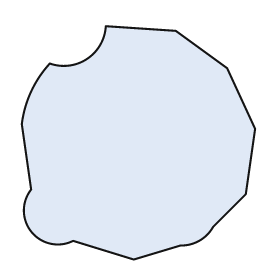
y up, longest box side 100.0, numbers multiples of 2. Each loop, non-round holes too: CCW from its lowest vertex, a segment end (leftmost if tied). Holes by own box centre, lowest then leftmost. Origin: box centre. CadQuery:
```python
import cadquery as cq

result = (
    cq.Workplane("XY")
    .moveTo(-2.0, -50.0)
    .lineTo(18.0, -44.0)
    .threePointArc((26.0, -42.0), (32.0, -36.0))
    .lineTo(46.0, -22.0)
    .lineTo(50.0, 6.0)
    .lineTo(38.0, 32.0)
    .lineTo(16.0, 48.0)
    .lineTo(-14.0, 50.0)
    .threePointArc((-22.0, 36.0), (-38.0, 34.0))
    .threePointArc((-46.0, 22.0), (-50.0, 8.0))
    .lineTo(-46.0, -20.0)
    .threePointArc((-46.0, -38.0), (-28.0, -42.0))
    .close()
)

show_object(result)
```